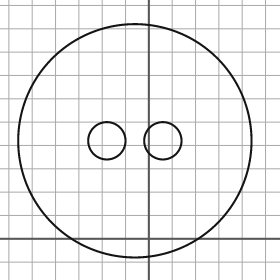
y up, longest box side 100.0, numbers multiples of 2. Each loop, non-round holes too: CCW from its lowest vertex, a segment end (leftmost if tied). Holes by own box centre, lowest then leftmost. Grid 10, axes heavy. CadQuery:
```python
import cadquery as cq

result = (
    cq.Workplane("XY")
    .moveTo(-6.0, 42.0)
    .circle(50.0)
    .moveTo(-18.0, 42.0)
    .circle(8.0)
    .moveTo(6.0, 42.0)
    .circle(8.0)
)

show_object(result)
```